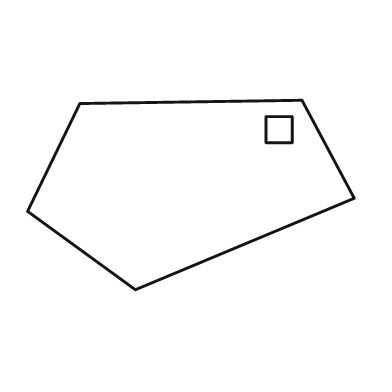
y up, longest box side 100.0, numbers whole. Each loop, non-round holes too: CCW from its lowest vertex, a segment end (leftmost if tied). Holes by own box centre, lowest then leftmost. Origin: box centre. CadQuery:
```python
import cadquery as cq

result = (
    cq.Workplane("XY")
    .moveTo(-17.0, -29.0)
    .lineTo(50.0, -1.0)
    .lineTo(34.0, 29.0)
    .lineTo(-34.0, 28.0)
    .lineTo(-50.0, -5.0)
    .close()
    .moveTo(23.0, 16.0)
    .lineTo(31.0, 16.0)
    .lineTo(31.0, 24.0)
    .lineTo(23.0, 24.0)
    .close()
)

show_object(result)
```